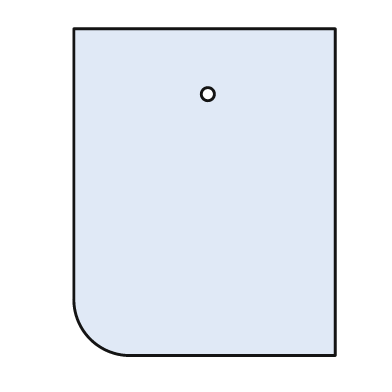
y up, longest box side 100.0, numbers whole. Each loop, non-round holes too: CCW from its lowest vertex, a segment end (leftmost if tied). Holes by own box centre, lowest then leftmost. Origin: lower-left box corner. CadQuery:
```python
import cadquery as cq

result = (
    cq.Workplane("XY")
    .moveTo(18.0, 0.0)
    .lineTo(80.0, 0.0)
    .lineTo(80.0, 100.0)
    .lineTo(0.0, 100.0)
    .lineTo(0.0, 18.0)
    .threePointArc((5.0, 5.0), (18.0, 0.0))
    .close()
    .moveTo(41.0, 80.0)
    .circle(2.0)
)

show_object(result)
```